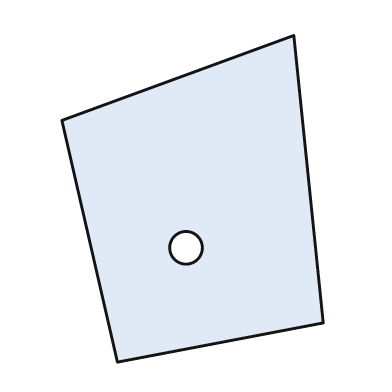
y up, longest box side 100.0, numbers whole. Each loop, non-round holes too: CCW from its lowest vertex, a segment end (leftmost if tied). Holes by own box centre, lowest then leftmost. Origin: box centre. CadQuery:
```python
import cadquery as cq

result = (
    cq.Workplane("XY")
    .moveTo(-23.0, -50.0)
    .lineTo(40.0, -38.0)
    .lineTo(31.0, 50.0)
    .lineTo(-40.0, 24.0)
    .close()
    .moveTo(-2.0, -15.0)
    .circle(5.0)
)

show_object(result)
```